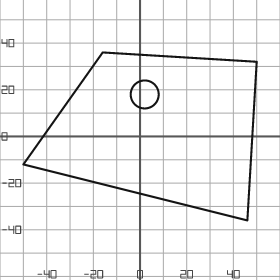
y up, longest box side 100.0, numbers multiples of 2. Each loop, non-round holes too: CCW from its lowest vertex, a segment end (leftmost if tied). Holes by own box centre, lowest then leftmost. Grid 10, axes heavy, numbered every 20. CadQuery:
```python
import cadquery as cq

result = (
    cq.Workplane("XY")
    .moveTo(46.0, -36.0)
    .lineTo(50.0, 32.0)
    .lineTo(-16.0, 36.0)
    .lineTo(-50.0, -12.0)
    .close()
    .moveTo(2.0, 18.0)
    .circle(6.0)
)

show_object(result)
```